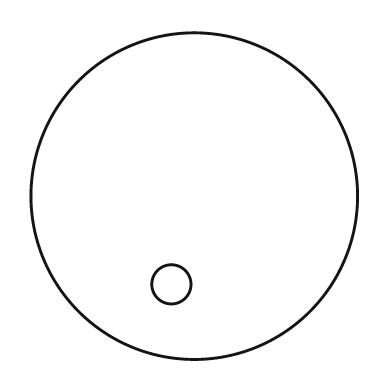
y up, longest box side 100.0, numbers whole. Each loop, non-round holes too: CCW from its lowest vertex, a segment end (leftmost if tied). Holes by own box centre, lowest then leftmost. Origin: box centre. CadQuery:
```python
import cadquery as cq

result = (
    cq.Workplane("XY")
    .moveTo(0.0, 0.0)
    .circle(50.0)
    .moveTo(-7.0, -27.0)
    .circle(6.0)
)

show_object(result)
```